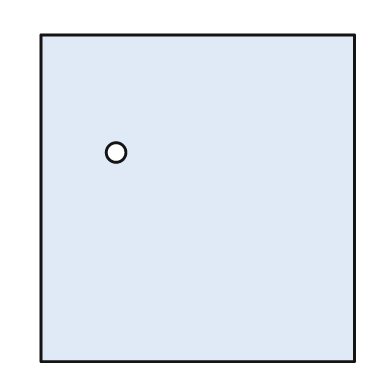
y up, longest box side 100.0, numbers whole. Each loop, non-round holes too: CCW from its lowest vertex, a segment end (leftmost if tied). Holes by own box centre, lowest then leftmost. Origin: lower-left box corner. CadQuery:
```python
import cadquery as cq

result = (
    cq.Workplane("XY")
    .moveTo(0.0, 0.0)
    .lineTo(96.0, 0.0)
    .lineTo(96.0, 100.0)
    .lineTo(0.0, 100.0)
    .close()
    .moveTo(23.0, 64.0)
    .circle(3.0)
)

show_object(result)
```